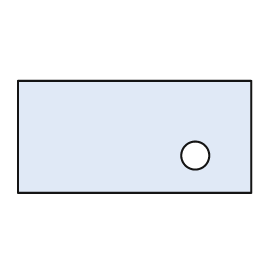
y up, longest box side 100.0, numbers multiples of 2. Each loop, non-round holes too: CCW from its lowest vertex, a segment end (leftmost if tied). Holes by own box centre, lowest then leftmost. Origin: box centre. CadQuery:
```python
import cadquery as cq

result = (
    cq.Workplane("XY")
    .moveTo(-50.0, -24.0)
    .lineTo(50.0, -24.0)
    .lineTo(50.0, 24.0)
    .lineTo(-50.0, 24.0)
    .close()
    .moveTo(26.0, -8.0)
    .circle(6.0)
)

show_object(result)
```